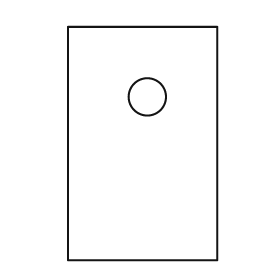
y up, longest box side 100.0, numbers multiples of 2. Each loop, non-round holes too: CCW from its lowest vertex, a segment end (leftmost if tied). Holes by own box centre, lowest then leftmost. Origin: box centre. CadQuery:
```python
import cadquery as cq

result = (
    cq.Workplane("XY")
    .moveTo(-32.0, -50.0)
    .lineTo(32.0, -50.0)
    .lineTo(32.0, 50.0)
    .lineTo(-32.0, 50.0)
    .close()
    .moveTo(2.0, 20.0)
    .circle(8.0)
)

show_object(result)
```